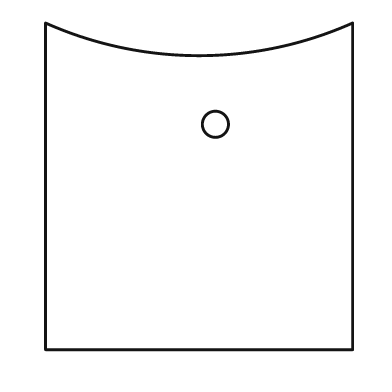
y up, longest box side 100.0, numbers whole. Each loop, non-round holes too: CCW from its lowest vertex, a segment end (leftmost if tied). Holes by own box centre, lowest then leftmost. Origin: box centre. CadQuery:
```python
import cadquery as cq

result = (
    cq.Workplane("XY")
    .moveTo(-47.0, -50.0)
    .lineTo(47.0, -50.0)
    .lineTo(47.0, 50.0)
    .threePointArc((0.0, 40.0), (-47.0, 50.0))
    .close()
    .moveTo(5.0, 19.0)
    .circle(4.0)
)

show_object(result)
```